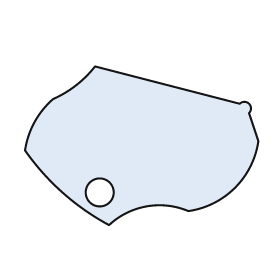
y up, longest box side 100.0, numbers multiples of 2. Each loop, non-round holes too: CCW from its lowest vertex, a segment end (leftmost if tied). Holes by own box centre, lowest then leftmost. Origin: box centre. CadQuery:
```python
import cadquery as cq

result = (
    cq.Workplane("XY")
    .moveTo(-14.0, -34.0)
    .threePointArc((2.0, -26.0), (20.0, -28.0))
    .threePointArc((40.0, -18.0), (50.0, 2.0))
    .lineTo(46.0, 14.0)
    .threePointArc((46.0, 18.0), (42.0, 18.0))
    .lineTo(-20.0, 34.0)
    .threePointArc((-28.0, 26.0), (-38.0, 20.0))
    .threePointArc((-46.0, 10.0), (-50.0, -2.0))
    .threePointArc((-34.0, -20.0), (-14.0, -34.0))
    .close()
    .moveTo(-18.0, -20.0)
    .circle(6.0)
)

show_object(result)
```